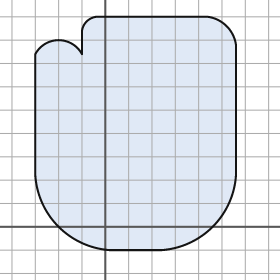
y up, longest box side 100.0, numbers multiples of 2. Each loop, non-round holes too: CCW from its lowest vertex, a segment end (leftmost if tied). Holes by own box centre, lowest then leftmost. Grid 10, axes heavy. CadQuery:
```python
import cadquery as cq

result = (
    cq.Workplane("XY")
    .moveTo(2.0, -10.0)
    .lineTo(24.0, -10.0)
    .threePointArc((46.0, 0.0), (56.0, 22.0))
    .lineTo(56.0, 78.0)
    .threePointArc((52.0, 86.0), (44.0, 90.0))
    .lineTo(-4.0, 90.0)
    .threePointArc((-8.0, 88.0), (-10.0, 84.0))
    .lineTo(-10.0, 74.0)
    .threePointArc((-20.0, 80.0), (-30.0, 74.0))
    .lineTo(-30.0, 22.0)
    .threePointArc((-20.0, 0.0), (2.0, -10.0))
    .close()
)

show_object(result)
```